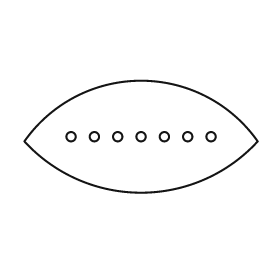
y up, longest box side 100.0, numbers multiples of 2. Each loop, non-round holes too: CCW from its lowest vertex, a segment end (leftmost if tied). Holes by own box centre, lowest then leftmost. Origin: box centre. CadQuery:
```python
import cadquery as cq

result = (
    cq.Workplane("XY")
    .moveTo(-50.0, -2.0)
    .threePointArc((0.0, -24.0), (50.0, -2.0))
    .threePointArc((0.0, 24.0), (-50.0, -2.0))
    .close()
    .moveTo(-30.0, 0.0)
    .circle(2.0)
    .moveTo(-20.0, 0.0)
    .circle(2.0)
    .moveTo(-10.0, 0.0)
    .circle(2.0)
    .moveTo(0.0, 0.0)
    .circle(2.0)
    .moveTo(10.0, 0.0)
    .circle(2.0)
    .moveTo(20.0, 0.0)
    .circle(2.0)
    .moveTo(30.0, 0.0)
    .circle(2.0)
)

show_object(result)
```